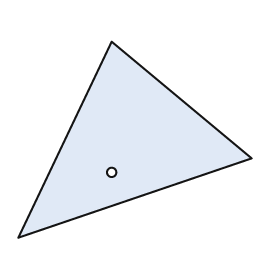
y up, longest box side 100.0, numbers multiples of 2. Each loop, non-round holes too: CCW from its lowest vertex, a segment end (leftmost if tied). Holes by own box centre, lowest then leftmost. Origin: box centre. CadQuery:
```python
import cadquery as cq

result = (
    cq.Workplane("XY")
    .moveTo(-50.0, -42.0)
    .lineTo(50.0, -8.0)
    .lineTo(-10.0, 42.0)
    .close()
    .moveTo(-10.0, -14.0)
    .circle(2.0)
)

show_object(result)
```